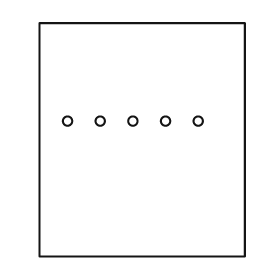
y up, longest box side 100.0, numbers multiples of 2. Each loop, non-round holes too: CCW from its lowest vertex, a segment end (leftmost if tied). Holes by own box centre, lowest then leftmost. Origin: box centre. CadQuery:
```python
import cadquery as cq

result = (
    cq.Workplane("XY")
    .moveTo(-44.0, -50.0)
    .lineTo(44.0, -50.0)
    .lineTo(44.0, 50.0)
    .lineTo(-44.0, 50.0)
    .close()
    .moveTo(-32.0, 8.0)
    .circle(2.0)
    .moveTo(-18.0, 8.0)
    .circle(2.0)
    .moveTo(-4.0, 8.0)
    .circle(2.0)
    .moveTo(10.0, 8.0)
    .circle(2.0)
    .moveTo(24.0, 8.0)
    .circle(2.0)
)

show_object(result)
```